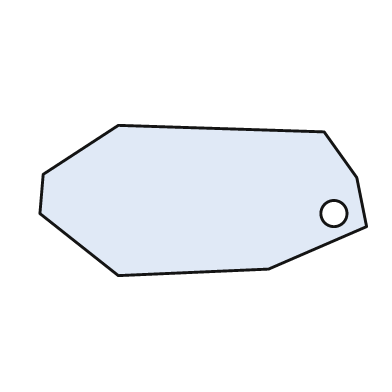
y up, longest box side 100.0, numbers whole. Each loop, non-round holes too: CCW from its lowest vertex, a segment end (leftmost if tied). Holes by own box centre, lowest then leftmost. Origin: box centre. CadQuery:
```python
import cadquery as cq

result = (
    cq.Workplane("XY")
    .moveTo(-26.0, -23.0)
    .lineTo(20.0, -21.0)
    .lineTo(50.0, -8.0)
    .lineTo(47.0, 7.0)
    .lineTo(37.0, 21.0)
    .lineTo(-26.0, 23.0)
    .lineTo(-49.0, 8.0)
    .lineTo(-50.0, -4.0)
    .close()
    .moveTo(40.0, -4.0)
    .circle(4.0)
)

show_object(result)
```